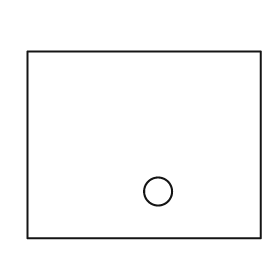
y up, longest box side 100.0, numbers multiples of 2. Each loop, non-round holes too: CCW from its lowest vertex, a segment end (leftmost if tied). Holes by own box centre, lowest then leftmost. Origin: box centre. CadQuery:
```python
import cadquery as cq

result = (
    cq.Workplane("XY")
    .moveTo(-50.0, -40.0)
    .lineTo(50.0, -40.0)
    .lineTo(50.0, 40.0)
    .lineTo(-50.0, 40.0)
    .close()
    .moveTo(6.0, -20.0)
    .circle(6.0)
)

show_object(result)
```